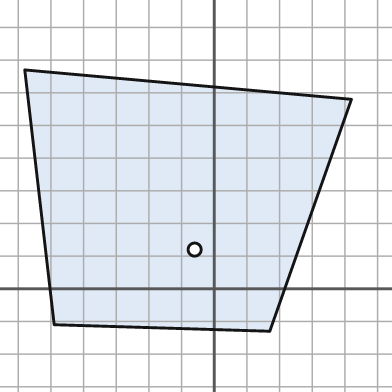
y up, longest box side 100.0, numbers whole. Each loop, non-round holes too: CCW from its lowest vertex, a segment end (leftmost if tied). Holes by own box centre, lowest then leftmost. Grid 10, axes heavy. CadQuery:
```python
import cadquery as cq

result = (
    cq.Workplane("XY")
    .moveTo(17.0, -13.0)
    .lineTo(42.0, 58.0)
    .lineTo(-58.0, 67.0)
    .lineTo(-49.0, -11.0)
    .close()
    .moveTo(-6.0, 12.0)
    .circle(2.0)
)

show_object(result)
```